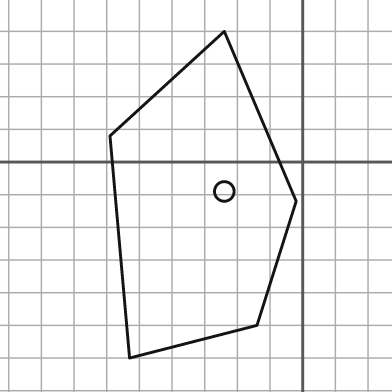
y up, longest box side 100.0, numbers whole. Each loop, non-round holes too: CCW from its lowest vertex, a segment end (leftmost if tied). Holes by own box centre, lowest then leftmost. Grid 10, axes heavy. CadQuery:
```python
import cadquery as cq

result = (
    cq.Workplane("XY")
    .moveTo(-53.0, -60.0)
    .lineTo(-14.0, -50.0)
    .lineTo(-2.0, -12.0)
    .lineTo(-24.0, 40.0)
    .lineTo(-59.0, 8.0)
    .close()
    .moveTo(-24.0, -9.0)
    .circle(3.0)
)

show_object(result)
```